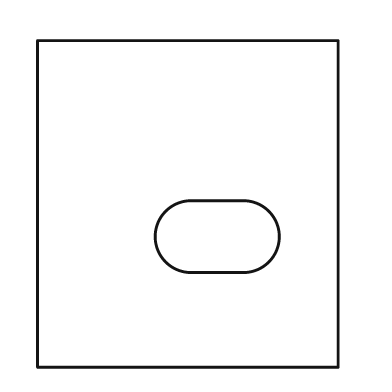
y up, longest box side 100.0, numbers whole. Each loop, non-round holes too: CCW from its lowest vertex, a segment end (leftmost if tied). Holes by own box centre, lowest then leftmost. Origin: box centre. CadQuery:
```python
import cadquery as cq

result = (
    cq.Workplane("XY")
    .moveTo(-46.0, -50.0)
    .lineTo(46.0, -50.0)
    .lineTo(46.0, 50.0)
    .lineTo(-46.0, 50.0)
    .close()
    .moveTo(1.0, -21.0)
    .lineTo(17.0, -21.0)
    .threePointArc((28.0, -10.0), (17.0, 1.0))
    .lineTo(1.0, 1.0)
    .threePointArc((-10.0, -10.0), (1.0, -21.0))
    .close()
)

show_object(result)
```